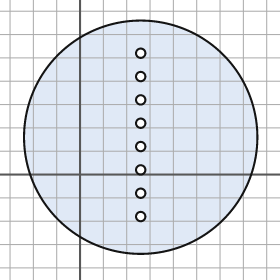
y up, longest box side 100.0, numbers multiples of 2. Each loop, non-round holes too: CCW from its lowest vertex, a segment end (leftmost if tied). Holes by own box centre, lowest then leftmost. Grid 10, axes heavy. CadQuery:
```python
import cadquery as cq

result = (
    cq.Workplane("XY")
    .moveTo(26.0, 16.0)
    .circle(50.0)
    .moveTo(26.0, -18.0)
    .circle(2.0)
    .moveTo(26.0, -8.0)
    .circle(2.0)
    .moveTo(26.0, 2.0)
    .circle(2.0)
    .moveTo(26.0, 12.0)
    .circle(2.0)
    .moveTo(26.0, 22.0)
    .circle(2.0)
    .moveTo(26.0, 32.0)
    .circle(2.0)
    .moveTo(26.0, 42.0)
    .circle(2.0)
    .moveTo(26.0, 52.0)
    .circle(2.0)
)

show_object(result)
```